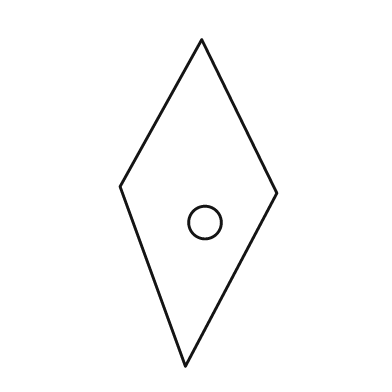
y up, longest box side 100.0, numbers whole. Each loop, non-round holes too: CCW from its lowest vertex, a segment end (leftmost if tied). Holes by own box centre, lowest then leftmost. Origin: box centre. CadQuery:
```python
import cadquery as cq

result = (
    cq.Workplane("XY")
    .moveTo(-4.0, -50.0)
    .lineTo(24.0, 3.0)
    .lineTo(1.0, 50.0)
    .lineTo(-24.0, 5.0)
    .close()
    .moveTo(2.0, -6.0)
    .circle(5.0)
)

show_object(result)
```